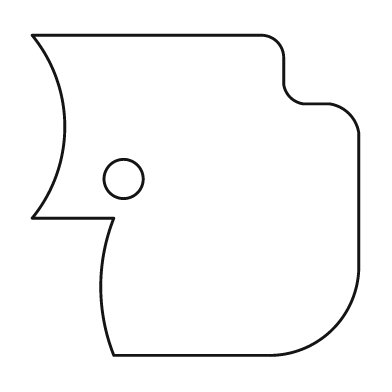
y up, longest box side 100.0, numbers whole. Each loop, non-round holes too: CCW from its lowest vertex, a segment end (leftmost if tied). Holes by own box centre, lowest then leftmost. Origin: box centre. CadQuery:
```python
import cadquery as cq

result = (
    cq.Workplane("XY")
    .moveTo(-25.0, -49.0)
    .lineTo(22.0, -49.0)
    .threePointArc((42.0, -41.0), (50.0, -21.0))
    .lineTo(50.0, 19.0)
    .threePointArc((47.0, 25.0), (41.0, 28.0))
    .lineTo(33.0, 28.0)
    .threePointArc((29.0, 30.0), (27.0, 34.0))
    .lineTo(27.0, 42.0)
    .threePointArc((25.0, 47.0), (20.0, 49.0))
    .lineTo(-50.0, 49.0)
    .threePointArc((-40.0, 21.0), (-50.0, -7.0))
    .lineTo(-25.0, -7.0)
    .threePointArc((-29.0, -28.0), (-25.0, -49.0))
    .close()
    .moveTo(-22.0, 5.0)
    .circle(6.0)
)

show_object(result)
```